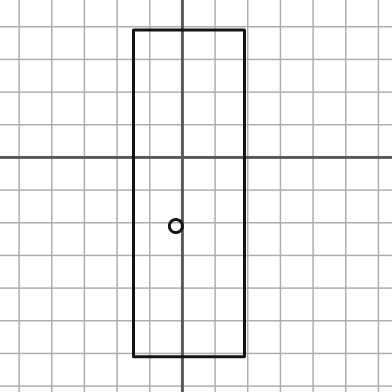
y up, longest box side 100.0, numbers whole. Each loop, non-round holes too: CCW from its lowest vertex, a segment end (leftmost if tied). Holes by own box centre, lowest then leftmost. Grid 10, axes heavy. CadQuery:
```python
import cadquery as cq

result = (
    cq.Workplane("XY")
    .moveTo(-15.0, -61.0)
    .lineTo(19.0, -61.0)
    .lineTo(19.0, 39.0)
    .lineTo(-15.0, 39.0)
    .close()
    .moveTo(-2.0, -21.0)
    .circle(2.0)
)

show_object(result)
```